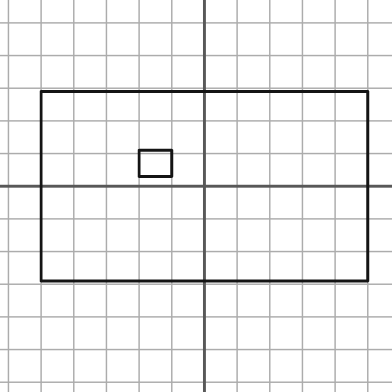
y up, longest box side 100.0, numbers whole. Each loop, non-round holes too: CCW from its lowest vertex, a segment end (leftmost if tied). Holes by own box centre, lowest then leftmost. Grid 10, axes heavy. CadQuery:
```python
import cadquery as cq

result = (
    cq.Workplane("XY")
    .moveTo(-50.0, -29.0)
    .lineTo(50.0, -29.0)
    .lineTo(50.0, 29.0)
    .lineTo(-50.0, 29.0)
    .close()
    .moveTo(-20.0, 3.0)
    .lineTo(-10.0, 3.0)
    .lineTo(-10.0, 11.0)
    .lineTo(-20.0, 11.0)
    .close()
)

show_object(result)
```